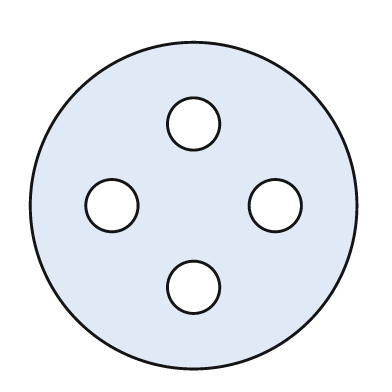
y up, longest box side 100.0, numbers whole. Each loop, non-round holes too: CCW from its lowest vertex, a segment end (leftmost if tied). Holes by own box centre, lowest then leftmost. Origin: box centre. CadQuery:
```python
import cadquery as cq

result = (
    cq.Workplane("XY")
    .moveTo(0.0, 0.0)
    .circle(50.0)
    .moveTo(0.0, -25.0)
    .circle(8.0)
    .moveTo(-25.0, 0.0)
    .circle(8.0)
    .moveTo(25.0, 0.0)
    .circle(8.0)
    .moveTo(0.0, 25.0)
    .circle(8.0)
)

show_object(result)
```